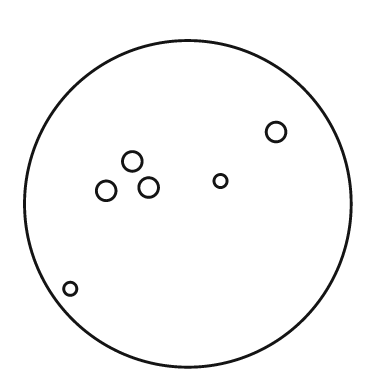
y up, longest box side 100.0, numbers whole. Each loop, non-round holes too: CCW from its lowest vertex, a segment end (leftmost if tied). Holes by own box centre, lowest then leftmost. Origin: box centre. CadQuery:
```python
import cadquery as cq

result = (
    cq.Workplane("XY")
    .moveTo(0.0, 0.0)
    .circle(50.0)
    .moveTo(-36.0, -26.0)
    .circle(2.0)
    .moveTo(-25.0, 4.0)
    .circle(3.0)
    .moveTo(-12.0, 5.0)
    .circle(3.0)
    .moveTo(10.0, 7.0)
    .circle(2.0)
    .moveTo(-17.0, 13.0)
    .circle(3.0)
    .moveTo(27.0, 22.0)
    .circle(3.0)
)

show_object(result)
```